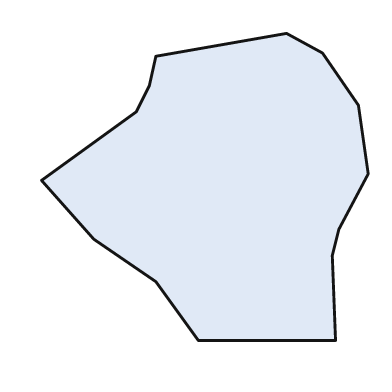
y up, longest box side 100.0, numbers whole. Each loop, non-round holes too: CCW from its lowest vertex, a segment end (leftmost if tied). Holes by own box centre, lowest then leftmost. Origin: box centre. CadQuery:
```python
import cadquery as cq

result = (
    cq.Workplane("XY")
    .moveTo(-2.0, -47.0)
    .lineTo(40.0, -47.0)
    .lineTo(39.0, -21.0)
    .lineTo(41.0, -13.0)
    .lineTo(50.0, 4.0)
    .lineTo(47.0, 25.0)
    .lineTo(36.0, 41.0)
    .lineTo(25.0, 47.0)
    .lineTo(-15.0, 40.0)
    .lineTo(-17.0, 31.0)
    .lineTo(-21.0, 23.0)
    .lineTo(-50.0, 2.0)
    .lineTo(-34.0, -16.0)
    .lineTo(-15.0, -29.0)
    .close()
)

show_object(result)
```